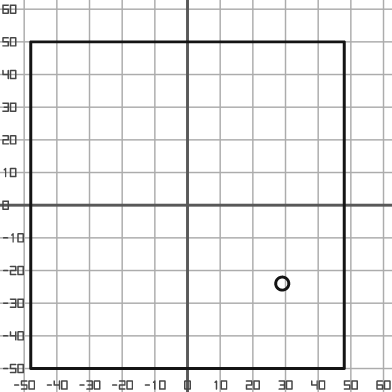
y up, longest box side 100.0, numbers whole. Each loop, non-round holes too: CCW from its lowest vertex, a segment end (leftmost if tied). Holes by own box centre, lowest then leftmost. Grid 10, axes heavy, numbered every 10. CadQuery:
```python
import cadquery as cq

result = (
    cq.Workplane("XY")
    .moveTo(-48.0, -50.0)
    .lineTo(48.0, -50.0)
    .lineTo(48.0, 50.0)
    .lineTo(-48.0, 50.0)
    .close()
    .moveTo(29.0, -24.0)
    .circle(2.0)
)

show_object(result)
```